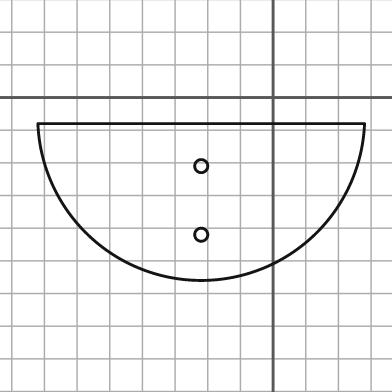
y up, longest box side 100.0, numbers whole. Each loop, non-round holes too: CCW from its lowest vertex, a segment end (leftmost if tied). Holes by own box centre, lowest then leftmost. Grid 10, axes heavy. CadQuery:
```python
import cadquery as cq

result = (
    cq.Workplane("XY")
    .moveTo(-72.0, -8.0)
    .threePointArc((-22.0, -56.0), (28.0, -8.0))
    .close()
    .moveTo(-22.0, -42.0)
    .circle(2.0)
    .moveTo(-22.0, -21.0)
    .circle(2.0)
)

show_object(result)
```